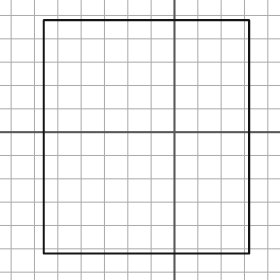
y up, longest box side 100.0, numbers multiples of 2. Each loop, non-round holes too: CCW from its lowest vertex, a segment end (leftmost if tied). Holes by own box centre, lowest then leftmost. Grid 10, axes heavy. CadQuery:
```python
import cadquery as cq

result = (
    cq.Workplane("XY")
    .moveTo(-56.0, -52.0)
    .lineTo(32.0, -52.0)
    .lineTo(32.0, 48.0)
    .lineTo(-56.0, 48.0)
    .close()
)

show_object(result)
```